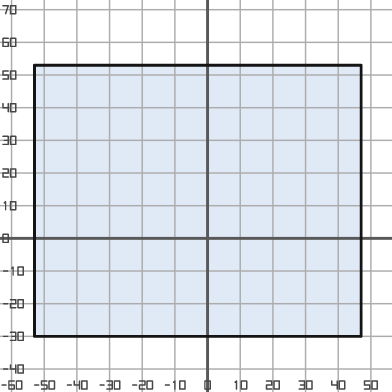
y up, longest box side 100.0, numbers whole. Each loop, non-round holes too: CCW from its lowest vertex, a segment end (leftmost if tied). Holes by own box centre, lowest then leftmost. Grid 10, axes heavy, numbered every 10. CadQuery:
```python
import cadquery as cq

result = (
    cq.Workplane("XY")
    .moveTo(-53.0, -30.0)
    .lineTo(47.0, -30.0)
    .lineTo(47.0, 53.0)
    .lineTo(-53.0, 53.0)
    .close()
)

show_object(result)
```